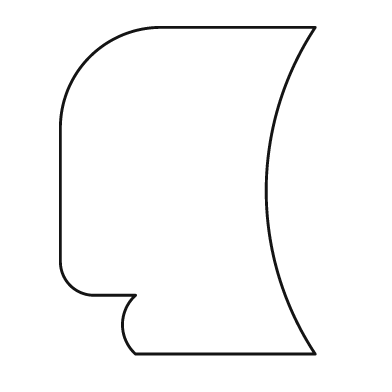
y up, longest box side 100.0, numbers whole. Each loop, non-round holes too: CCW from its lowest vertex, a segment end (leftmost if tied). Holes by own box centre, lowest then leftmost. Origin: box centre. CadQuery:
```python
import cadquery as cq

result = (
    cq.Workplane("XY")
    .moveTo(-16.0, -50.0)
    .lineTo(39.0, -50.0)
    .threePointArc((24.0, 0.0), (39.0, 50.0))
    .lineTo(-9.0, 50.0)
    .threePointArc((-30.0, 41.0), (-39.0, 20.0))
    .lineTo(-39.0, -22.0)
    .threePointArc((-36.0, -29.0), (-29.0, -32.0))
    .lineTo(-16.0, -32.0)
    .threePointArc((-20.0, -41.0), (-16.0, -50.0))
    .close()
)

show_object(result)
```